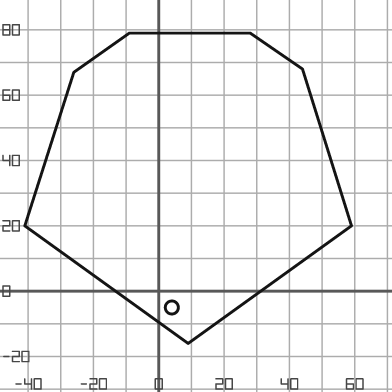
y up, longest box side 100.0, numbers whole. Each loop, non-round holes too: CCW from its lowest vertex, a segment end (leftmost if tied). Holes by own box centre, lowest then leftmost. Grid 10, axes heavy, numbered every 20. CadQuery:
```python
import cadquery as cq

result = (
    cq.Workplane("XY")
    .moveTo(9.0, -16.0)
    .lineTo(59.0, 20.0)
    .lineTo(44.0, 68.0)
    .lineTo(28.0, 79.0)
    .lineTo(-9.0, 79.0)
    .lineTo(-26.0, 67.0)
    .lineTo(-41.0, 20.0)
    .close()
    .moveTo(4.0, -5.0)
    .circle(2.0)
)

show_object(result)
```